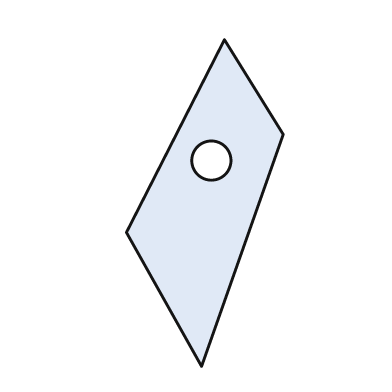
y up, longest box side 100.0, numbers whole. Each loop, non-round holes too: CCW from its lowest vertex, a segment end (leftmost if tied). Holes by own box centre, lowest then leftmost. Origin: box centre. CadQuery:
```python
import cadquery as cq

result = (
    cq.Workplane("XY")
    .moveTo(-1.0, -50.0)
    .lineTo(24.0, 21.0)
    .lineTo(6.0, 50.0)
    .lineTo(-24.0, -9.0)
    .close()
    .moveTo(2.0, 13.0)
    .circle(6.0)
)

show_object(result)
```